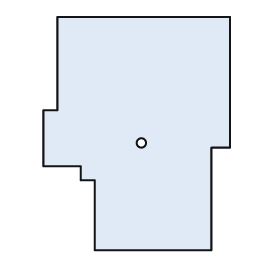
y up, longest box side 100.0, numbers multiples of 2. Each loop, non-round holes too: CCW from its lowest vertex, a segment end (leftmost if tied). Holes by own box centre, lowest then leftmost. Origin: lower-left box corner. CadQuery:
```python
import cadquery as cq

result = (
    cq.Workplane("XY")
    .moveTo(22.0, 0.0)
    .lineTo(72.0, 0.0)
    .lineTo(72.0, 44.0)
    .lineTo(80.0, 44.0)
    .lineTo(80.0, 100.0)
    .lineTo(6.0, 100.0)
    .lineTo(6.0, 60.0)
    .lineTo(0.0, 60.0)
    .lineTo(0.0, 36.0)
    .lineTo(16.0, 36.0)
    .lineTo(16.0, 30.0)
    .lineTo(22.0, 30.0)
    .close()
    .moveTo(42.0, 46.0)
    .circle(2.0)
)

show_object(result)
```